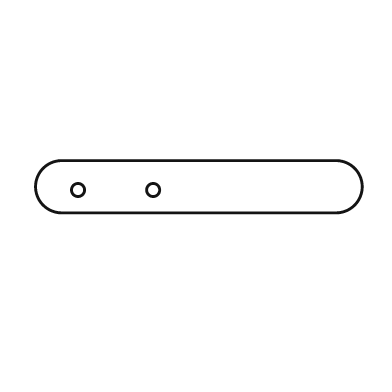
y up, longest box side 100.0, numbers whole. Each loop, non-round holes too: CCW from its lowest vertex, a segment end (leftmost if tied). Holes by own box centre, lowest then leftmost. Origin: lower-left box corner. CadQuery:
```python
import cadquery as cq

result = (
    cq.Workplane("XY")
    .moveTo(8.0, 0.0)
    .lineTo(92.0, 0.0)
    .threePointArc((100.0, 8.0), (92.0, 16.0))
    .lineTo(8.0, 16.0)
    .threePointArc((0.0, 8.0), (8.0, 0.0))
    .close()
    .moveTo(13.0, 7.0)
    .circle(2.0)
    .moveTo(36.0, 7.0)
    .circle(2.0)
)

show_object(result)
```